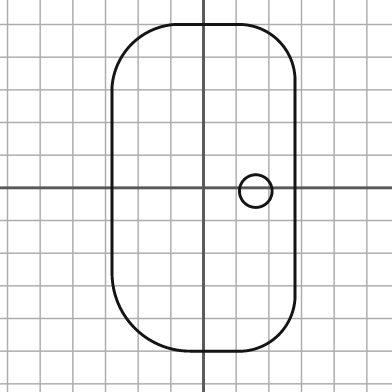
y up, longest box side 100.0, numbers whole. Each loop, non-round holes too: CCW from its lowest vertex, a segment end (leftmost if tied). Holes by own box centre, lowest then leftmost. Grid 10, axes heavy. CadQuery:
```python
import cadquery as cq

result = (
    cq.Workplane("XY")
    .moveTo(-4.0, -50.0)
    .lineTo(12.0, -50.0)
    .threePointArc((23.0, -45.0), (28.0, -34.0))
    .lineTo(28.0, 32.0)
    .threePointArc((23.0, 45.0), (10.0, 50.0))
    .lineTo(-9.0, 50.0)
    .threePointArc((-22.0, 44.0), (-28.0, 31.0))
    .lineTo(-28.0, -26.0)
    .threePointArc((-21.0, -43.0), (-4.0, -50.0))
    .close()
    .moveTo(16.0, -1.0)
    .circle(5.0)
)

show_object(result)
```